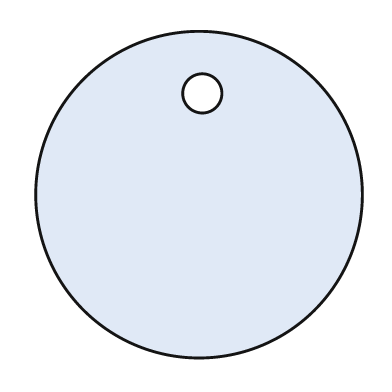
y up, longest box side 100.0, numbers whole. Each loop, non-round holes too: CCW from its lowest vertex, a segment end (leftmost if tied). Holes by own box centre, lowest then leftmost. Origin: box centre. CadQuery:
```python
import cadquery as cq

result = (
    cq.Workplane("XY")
    .moveTo(0.0, 0.0)
    .circle(50.0)
    .moveTo(1.0, 31.0)
    .circle(6.0)
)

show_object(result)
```